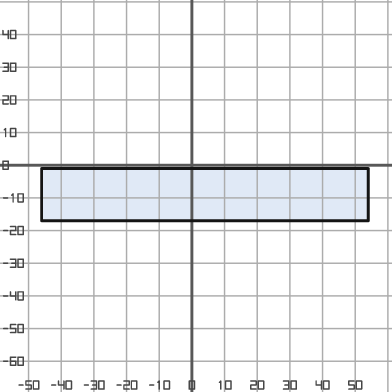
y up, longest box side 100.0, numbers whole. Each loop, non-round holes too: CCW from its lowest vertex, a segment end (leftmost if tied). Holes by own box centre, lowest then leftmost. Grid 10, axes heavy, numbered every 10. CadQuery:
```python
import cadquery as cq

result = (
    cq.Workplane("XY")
    .moveTo(-46.0, -17.0)
    .lineTo(54.0, -17.0)
    .lineTo(54.0, -1.0)
    .lineTo(-46.0, -1.0)
    .close()
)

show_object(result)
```